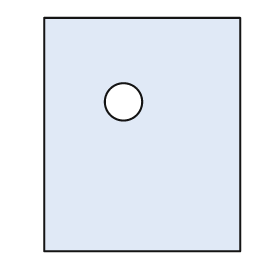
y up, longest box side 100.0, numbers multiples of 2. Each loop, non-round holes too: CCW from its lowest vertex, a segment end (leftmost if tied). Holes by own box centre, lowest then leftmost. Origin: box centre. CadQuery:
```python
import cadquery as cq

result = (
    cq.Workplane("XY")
    .moveTo(-42.0, -50.0)
    .lineTo(42.0, -50.0)
    .lineTo(42.0, 50.0)
    .lineTo(-42.0, 50.0)
    .close()
    .moveTo(-8.0, 14.0)
    .circle(8.0)
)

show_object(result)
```